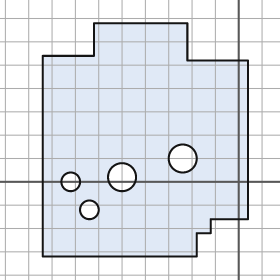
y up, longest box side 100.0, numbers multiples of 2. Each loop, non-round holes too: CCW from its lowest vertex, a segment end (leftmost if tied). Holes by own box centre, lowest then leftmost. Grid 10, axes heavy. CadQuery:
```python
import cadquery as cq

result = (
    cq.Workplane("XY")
    .moveTo(-84.0, -32.0)
    .lineTo(-18.0, -32.0)
    .lineTo(-18.0, -22.0)
    .lineTo(-12.0, -22.0)
    .lineTo(-12.0, -16.0)
    .lineTo(4.0, -16.0)
    .lineTo(4.0, 52.0)
    .lineTo(-22.0, 52.0)
    .lineTo(-22.0, 68.0)
    .lineTo(-62.0, 68.0)
    .lineTo(-62.0, 54.0)
    .lineTo(-84.0, 54.0)
    .close()
    .moveTo(-64.0, -12.0)
    .circle(4.0)
    .moveTo(-72.0, 0.0)
    .circle(4.0)
    .moveTo(-50.0, 2.0)
    .circle(6.0)
    .moveTo(-24.0, 10.0)
    .circle(6.0)
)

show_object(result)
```